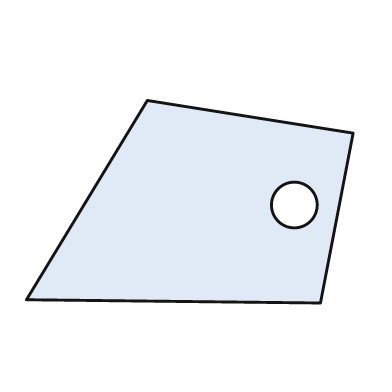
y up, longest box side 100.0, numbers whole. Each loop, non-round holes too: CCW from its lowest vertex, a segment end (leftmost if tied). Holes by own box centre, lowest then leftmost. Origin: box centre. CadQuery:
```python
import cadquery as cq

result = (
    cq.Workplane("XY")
    .moveTo(40.0, -31.0)
    .lineTo(50.0, 21.0)
    .lineTo(-13.0, 31.0)
    .lineTo(-50.0, -30.0)
    .close()
    .moveTo(32.0, -1.0)
    .circle(7.0)
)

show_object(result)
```